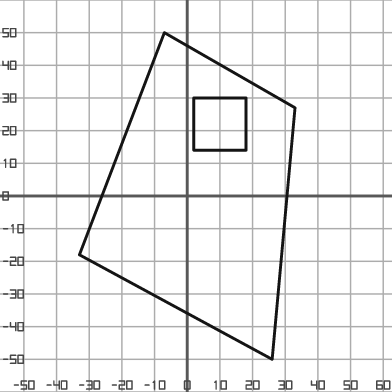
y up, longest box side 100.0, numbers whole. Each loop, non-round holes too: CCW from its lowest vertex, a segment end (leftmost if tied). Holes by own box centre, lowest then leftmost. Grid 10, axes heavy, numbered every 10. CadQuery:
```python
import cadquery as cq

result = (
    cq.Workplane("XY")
    .moveTo(26.0, -50.0)
    .lineTo(33.0, 27.0)
    .lineTo(-7.0, 50.0)
    .lineTo(-33.0, -18.0)
    .close()
    .moveTo(2.0, 14.0)
    .lineTo(18.0, 14.0)
    .lineTo(18.0, 30.0)
    .lineTo(2.0, 30.0)
    .close()
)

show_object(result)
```